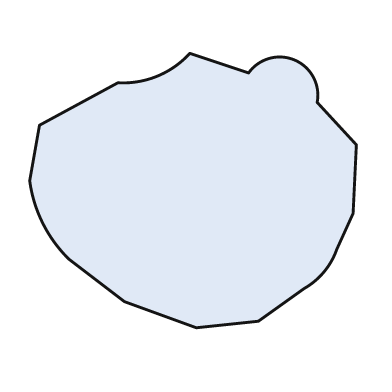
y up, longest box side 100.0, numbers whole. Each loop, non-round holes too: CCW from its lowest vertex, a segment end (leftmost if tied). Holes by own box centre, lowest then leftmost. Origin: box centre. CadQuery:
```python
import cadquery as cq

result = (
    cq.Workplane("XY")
    .moveTo(1.0, -42.0)
    .lineTo(20.0, -40.0)
    .lineTo(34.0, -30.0)
    .threePointArc((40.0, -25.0), (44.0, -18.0))
    .lineTo(49.0, -7.0)
    .lineTo(50.0, 14.0)
    .lineTo(38.0, 27.0)
    .threePointArc((31.0, 40.0), (17.0, 36.0))
    .lineTo(-1.0, 42.0)
    .threePointArc((-11.0, 35.0), (-23.0, 33.0))
    .lineTo(-47.0, 20.0)
    .lineTo(-50.0, 3.0)
    .threePointArc((-46.0, -10.0), (-38.0, -21.0))
    .lineTo(-21.0, -34.0)
    .close()
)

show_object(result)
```